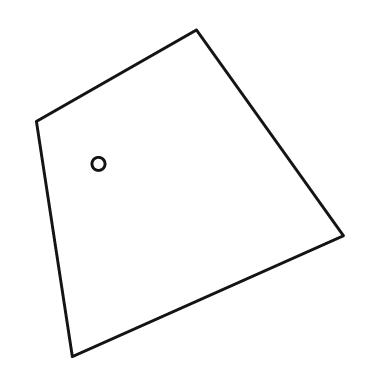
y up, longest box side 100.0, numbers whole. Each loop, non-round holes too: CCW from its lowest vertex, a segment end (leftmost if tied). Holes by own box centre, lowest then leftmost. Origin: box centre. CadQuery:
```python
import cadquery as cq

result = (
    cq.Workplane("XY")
    .moveTo(-36.0, -50.0)
    .lineTo(47.0, -13.0)
    .lineTo(2.0, 50.0)
    .lineTo(-47.0, 22.0)
    .close()
    .moveTo(-28.0, 9.0)
    .circle(2.0)
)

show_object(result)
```